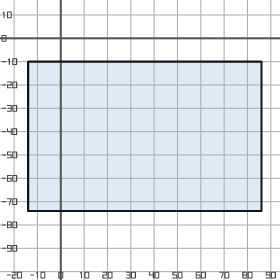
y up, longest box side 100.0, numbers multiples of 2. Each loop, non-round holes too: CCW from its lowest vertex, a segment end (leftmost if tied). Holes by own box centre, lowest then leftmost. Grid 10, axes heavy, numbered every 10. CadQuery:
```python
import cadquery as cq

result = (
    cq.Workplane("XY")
    .moveTo(-14.0, -74.0)
    .lineTo(86.0, -74.0)
    .lineTo(86.0, -10.0)
    .lineTo(-14.0, -10.0)
    .close()
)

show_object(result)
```